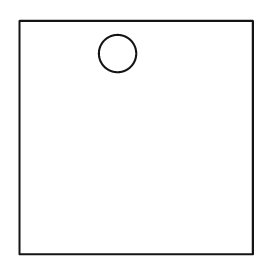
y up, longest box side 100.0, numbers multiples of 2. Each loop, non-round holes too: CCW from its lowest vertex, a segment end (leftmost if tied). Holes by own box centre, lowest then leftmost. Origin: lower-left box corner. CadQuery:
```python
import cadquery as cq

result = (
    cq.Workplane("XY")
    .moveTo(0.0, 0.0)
    .lineTo(100.0, 0.0)
    .lineTo(100.0, 100.0)
    .lineTo(0.0, 100.0)
    .close()
    .moveTo(42.0, 86.0)
    .circle(8.0)
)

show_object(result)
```